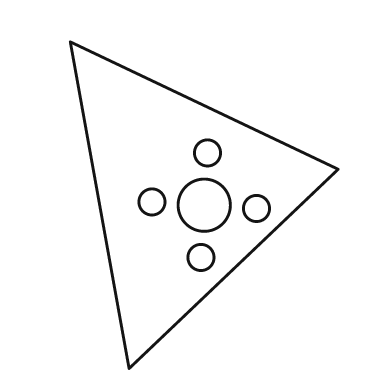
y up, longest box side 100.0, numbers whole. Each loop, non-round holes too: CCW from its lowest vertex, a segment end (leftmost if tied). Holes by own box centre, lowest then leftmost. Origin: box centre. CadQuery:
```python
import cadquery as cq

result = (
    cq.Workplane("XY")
    .moveTo(-23.0, -50.0)
    .lineTo(41.0, 11.0)
    .lineTo(-41.0, 50.0)
    .close()
    .moveTo(-1.0, -16.0)
    .circle(4.0)
    .moveTo(16.0, -1.0)
    .circle(4.0)
    .moveTo(0.0, 0.0)
    .circle(8.0)
    .moveTo(-16.0, 1.0)
    .circle(4.0)
    .moveTo(1.0, 16.0)
    .circle(4.0)
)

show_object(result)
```